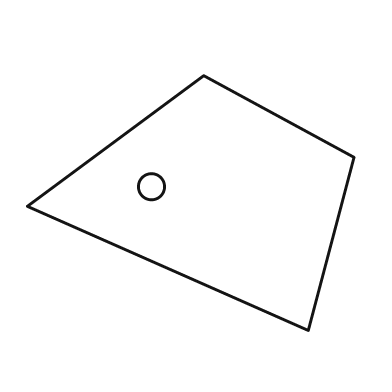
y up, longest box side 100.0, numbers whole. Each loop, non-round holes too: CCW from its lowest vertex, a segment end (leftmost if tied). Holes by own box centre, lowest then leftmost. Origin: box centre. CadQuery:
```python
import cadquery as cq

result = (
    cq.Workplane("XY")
    .moveTo(36.0, -39.0)
    .lineTo(50.0, 14.0)
    .lineTo(4.0, 39.0)
    .lineTo(-50.0, -1.0)
    .close()
    .moveTo(-12.0, 5.0)
    .circle(4.0)
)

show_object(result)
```